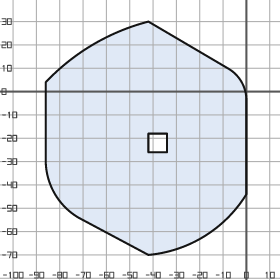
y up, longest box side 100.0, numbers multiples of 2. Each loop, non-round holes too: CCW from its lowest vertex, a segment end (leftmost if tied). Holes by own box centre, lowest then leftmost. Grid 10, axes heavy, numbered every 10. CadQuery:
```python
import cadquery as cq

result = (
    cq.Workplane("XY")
    .moveTo(-42.0, -70.0)
    .threePointArc((-18.0, -62.0), (0.0, -44.0))
    .lineTo(0.0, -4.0)
    .threePointArc((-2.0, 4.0), (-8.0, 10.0))
    .lineTo(-42.0, 30.0)
    .threePointArc((-66.0, 20.0), (-86.0, 4.0))
    .lineTo(-86.0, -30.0)
    .threePointArc((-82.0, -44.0), (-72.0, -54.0))
    .close()
    .moveTo(-42.0, -26.0)
    .lineTo(-34.0, -26.0)
    .lineTo(-34.0, -18.0)
    .lineTo(-42.0, -18.0)
    .close()
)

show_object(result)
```